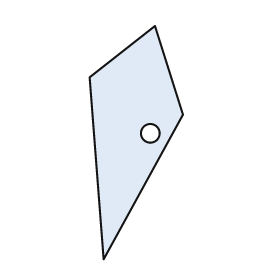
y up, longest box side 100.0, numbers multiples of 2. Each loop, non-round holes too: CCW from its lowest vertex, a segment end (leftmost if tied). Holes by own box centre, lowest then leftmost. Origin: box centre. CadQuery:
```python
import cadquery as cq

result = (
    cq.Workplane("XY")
    .moveTo(-14.0, -50.0)
    .lineTo(20.0, 12.0)
    .lineTo(8.0, 50.0)
    .lineTo(-20.0, 28.0)
    .close()
    .moveTo(6.0, 4.0)
    .circle(4.0)
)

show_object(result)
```